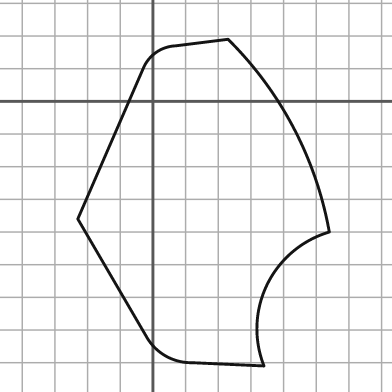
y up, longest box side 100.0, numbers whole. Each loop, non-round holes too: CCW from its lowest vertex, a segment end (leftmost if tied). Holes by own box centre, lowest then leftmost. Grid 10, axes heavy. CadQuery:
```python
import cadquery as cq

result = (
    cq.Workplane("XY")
    .moveTo(34.0, -81.0)
    .threePointArc((35.0, -56.0), (54.0, -40.0))
    .threePointArc((43.0, -8.0), (23.0, 19.0))
    .lineTo(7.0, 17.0)
    .threePointArc((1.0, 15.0), (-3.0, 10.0))
    .lineTo(-23.0, -36.0)
    .lineTo(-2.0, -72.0)
    .threePointArc((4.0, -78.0), (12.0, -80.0))
    .close()
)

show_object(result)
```